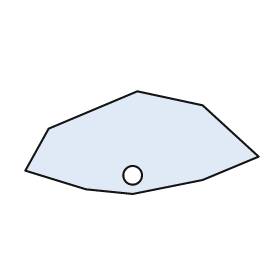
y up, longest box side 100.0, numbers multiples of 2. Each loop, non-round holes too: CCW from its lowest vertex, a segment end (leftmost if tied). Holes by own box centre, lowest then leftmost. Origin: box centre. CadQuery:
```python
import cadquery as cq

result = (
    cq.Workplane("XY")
    .moveTo(-4.0, -22.0)
    .lineTo(26.0, -16.0)
    .lineTo(50.0, -6.0)
    .lineTo(26.0, 16.0)
    .lineTo(-2.0, 22.0)
    .lineTo(-40.0, 6.0)
    .lineTo(-50.0, -12.0)
    .lineTo(-24.0, -20.0)
    .close()
    .moveTo(-4.0, -14.0)
    .circle(4.0)
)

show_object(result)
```